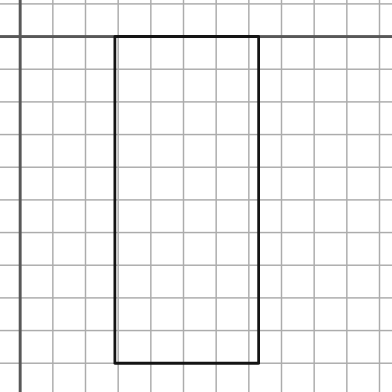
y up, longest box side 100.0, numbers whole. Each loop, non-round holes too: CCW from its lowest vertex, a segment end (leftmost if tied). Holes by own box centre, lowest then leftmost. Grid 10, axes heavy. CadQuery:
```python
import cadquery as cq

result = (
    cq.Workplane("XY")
    .moveTo(29.0, -100.0)
    .lineTo(73.0, -100.0)
    .lineTo(73.0, 0.0)
    .lineTo(29.0, 0.0)
    .close()
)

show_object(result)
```